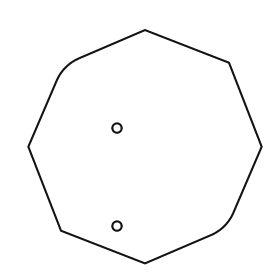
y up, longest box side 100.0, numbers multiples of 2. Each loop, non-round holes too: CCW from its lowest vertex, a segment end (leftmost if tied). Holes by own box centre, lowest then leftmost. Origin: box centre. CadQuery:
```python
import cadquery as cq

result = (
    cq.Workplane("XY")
    .moveTo(0.0, -50.0)
    .lineTo(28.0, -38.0)
    .threePointArc((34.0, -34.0), (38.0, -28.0))
    .lineTo(50.0, 0.0)
    .lineTo(36.0, 36.0)
    .lineTo(0.0, 50.0)
    .lineTo(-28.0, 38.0)
    .threePointArc((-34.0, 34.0), (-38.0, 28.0))
    .lineTo(-50.0, 0.0)
    .lineTo(-36.0, -36.0)
    .close()
    .moveTo(-12.0, -34.0)
    .circle(2.0)
    .moveTo(-12.0, 8.0)
    .circle(2.0)
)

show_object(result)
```